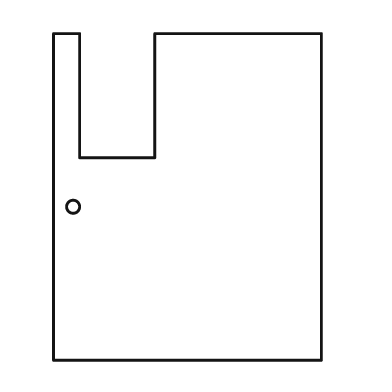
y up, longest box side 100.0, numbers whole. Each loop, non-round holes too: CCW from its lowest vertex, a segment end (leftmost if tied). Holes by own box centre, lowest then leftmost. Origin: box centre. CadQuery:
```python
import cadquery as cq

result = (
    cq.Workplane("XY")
    .moveTo(-41.0, -50.0)
    .lineTo(41.0, -50.0)
    .lineTo(41.0, 50.0)
    .lineTo(-10.0, 50.0)
    .lineTo(-10.0, 12.0)
    .lineTo(-33.0, 12.0)
    .lineTo(-33.0, 50.0)
    .lineTo(-41.0, 50.0)
    .close()
    .moveTo(-35.0, -3.0)
    .circle(2.0)
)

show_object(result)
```